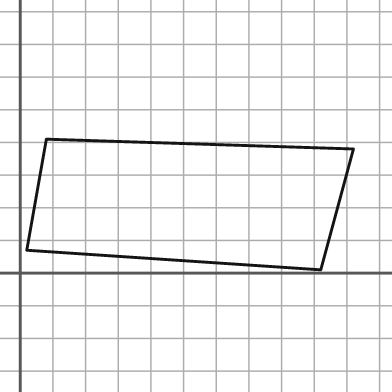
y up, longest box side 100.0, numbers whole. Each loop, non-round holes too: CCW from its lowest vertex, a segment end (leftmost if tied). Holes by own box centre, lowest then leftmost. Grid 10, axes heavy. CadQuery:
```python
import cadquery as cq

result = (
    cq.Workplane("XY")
    .moveTo(92.0, 1.0)
    .lineTo(102.0, 38.0)
    .lineTo(8.0, 41.0)
    .lineTo(2.0, 7.0)
    .close()
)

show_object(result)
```